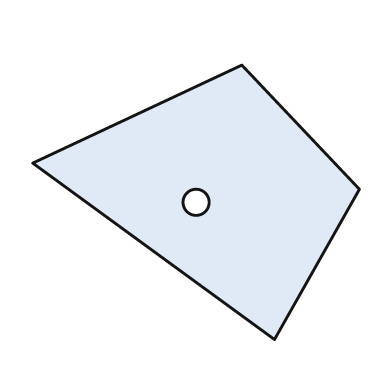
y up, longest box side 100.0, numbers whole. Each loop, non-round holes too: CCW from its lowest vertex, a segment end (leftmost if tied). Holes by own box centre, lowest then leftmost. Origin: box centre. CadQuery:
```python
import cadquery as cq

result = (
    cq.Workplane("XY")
    .moveTo(24.0, -42.0)
    .lineTo(50.0, 4.0)
    .lineTo(14.0, 42.0)
    .lineTo(-50.0, 12.0)
    .close()
    .moveTo(0.0, 0.0)
    .circle(4.0)
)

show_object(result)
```